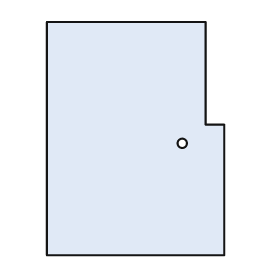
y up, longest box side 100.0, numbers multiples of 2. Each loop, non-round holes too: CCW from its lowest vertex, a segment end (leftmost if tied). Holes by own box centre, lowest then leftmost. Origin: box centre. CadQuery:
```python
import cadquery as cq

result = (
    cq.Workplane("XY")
    .moveTo(-38.0, -50.0)
    .lineTo(38.0, -50.0)
    .lineTo(38.0, 6.0)
    .lineTo(30.0, 6.0)
    .lineTo(30.0, 50.0)
    .lineTo(-38.0, 50.0)
    .close()
    .moveTo(20.0, -2.0)
    .circle(2.0)
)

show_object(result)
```